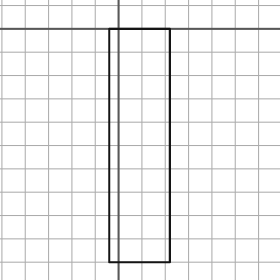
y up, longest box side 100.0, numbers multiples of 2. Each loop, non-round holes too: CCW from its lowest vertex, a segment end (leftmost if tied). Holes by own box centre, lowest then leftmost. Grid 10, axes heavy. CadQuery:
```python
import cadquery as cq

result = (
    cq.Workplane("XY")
    .moveTo(-4.0, -100.0)
    .lineTo(22.0, -100.0)
    .lineTo(22.0, 0.0)
    .lineTo(-4.0, 0.0)
    .close()
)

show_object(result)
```